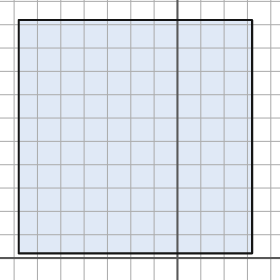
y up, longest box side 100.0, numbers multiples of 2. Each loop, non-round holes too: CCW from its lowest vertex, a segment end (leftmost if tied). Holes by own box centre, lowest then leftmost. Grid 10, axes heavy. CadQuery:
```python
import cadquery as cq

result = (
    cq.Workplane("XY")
    .moveTo(-68.0, 2.0)
    .lineTo(32.0, 2.0)
    .lineTo(32.0, 102.0)
    .lineTo(-68.0, 102.0)
    .close()
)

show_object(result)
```